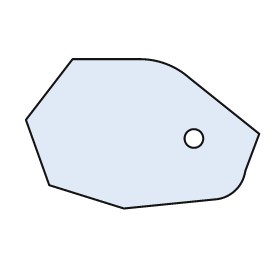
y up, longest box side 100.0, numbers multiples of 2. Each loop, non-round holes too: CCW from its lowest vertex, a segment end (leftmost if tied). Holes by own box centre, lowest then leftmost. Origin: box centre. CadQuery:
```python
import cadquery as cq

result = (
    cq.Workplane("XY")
    .moveTo(-8.0, -32.0)
    .lineTo(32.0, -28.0)
    .threePointArc((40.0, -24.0), (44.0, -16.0))
    .lineTo(50.0, 0.0)
    .lineTo(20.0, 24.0)
    .threePointArc((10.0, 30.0), (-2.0, 32.0))
    .lineTo(-30.0, 32.0)
    .lineTo(-50.0, 6.0)
    .lineTo(-40.0, -22.0)
    .close()
    .moveTo(22.0, -2.0)
    .circle(4.0)
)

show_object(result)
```